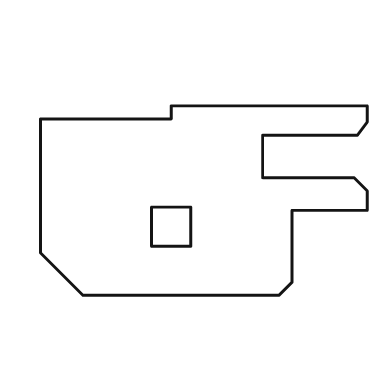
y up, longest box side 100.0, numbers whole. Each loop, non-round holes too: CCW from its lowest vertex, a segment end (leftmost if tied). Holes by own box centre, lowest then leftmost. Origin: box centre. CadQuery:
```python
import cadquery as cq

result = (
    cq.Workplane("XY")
    .moveTo(-37.0, -29.0)
    .lineTo(23.0, -29.0)
    .lineTo(27.0, -25.0)
    .lineTo(27.0, -3.0)
    .lineTo(50.0, -3.0)
    .lineTo(50.0, 3.0)
    .lineTo(46.0, 7.0)
    .lineTo(18.0, 7.0)
    .lineTo(18.0, 20.0)
    .lineTo(47.0, 20.0)
    .lineTo(50.0, 24.0)
    .lineTo(50.0, 29.0)
    .lineTo(-10.0, 29.0)
    .lineTo(-10.0, 25.0)
    .lineTo(-50.0, 25.0)
    .lineTo(-50.0, -16.0)
    .close()
    .moveTo(-16.0, -14.0)
    .lineTo(-4.0, -14.0)
    .lineTo(-4.0, -2.0)
    .lineTo(-16.0, -2.0)
    .close()
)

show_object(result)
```